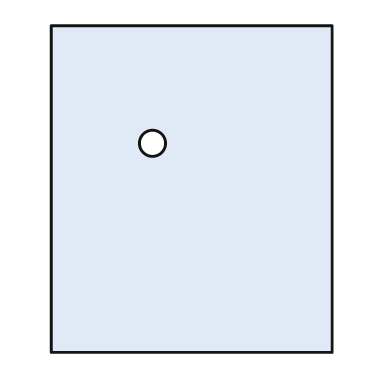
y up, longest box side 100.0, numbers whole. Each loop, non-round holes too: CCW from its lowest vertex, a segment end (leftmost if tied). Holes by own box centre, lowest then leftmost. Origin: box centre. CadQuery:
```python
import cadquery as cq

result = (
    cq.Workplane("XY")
    .moveTo(-43.0, -50.0)
    .lineTo(43.0, -50.0)
    .lineTo(43.0, 50.0)
    .lineTo(-43.0, 50.0)
    .close()
    .moveTo(-12.0, 14.0)
    .circle(4.0)
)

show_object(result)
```